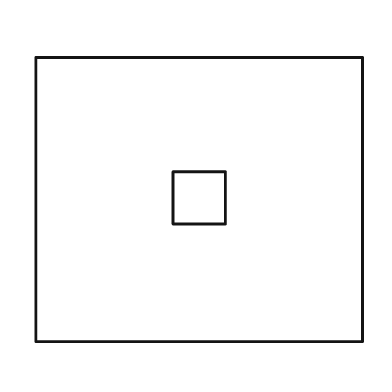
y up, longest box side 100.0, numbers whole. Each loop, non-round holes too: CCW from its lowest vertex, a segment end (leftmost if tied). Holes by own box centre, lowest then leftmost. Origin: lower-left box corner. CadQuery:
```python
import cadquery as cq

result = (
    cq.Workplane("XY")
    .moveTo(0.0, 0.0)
    .lineTo(100.0, 0.0)
    .lineTo(100.0, 87.0)
    .lineTo(0.0, 87.0)
    .close()
    .moveTo(42.0, 36.0)
    .lineTo(58.0, 36.0)
    .lineTo(58.0, 52.0)
    .lineTo(42.0, 52.0)
    .close()
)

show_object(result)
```